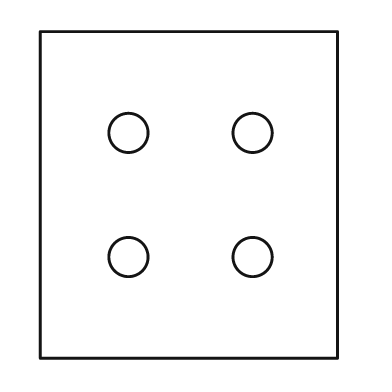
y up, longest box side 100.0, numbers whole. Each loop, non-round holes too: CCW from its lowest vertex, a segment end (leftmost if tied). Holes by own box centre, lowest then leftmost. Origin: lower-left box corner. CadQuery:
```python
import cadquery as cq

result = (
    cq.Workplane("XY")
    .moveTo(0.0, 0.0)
    .lineTo(91.0, 0.0)
    .lineTo(91.0, 100.0)
    .lineTo(0.0, 100.0)
    .close()
    .moveTo(27.0, 31.0)
    .circle(6.0)
    .moveTo(65.0, 31.0)
    .circle(6.0)
    .moveTo(27.0, 69.0)
    .circle(6.0)
    .moveTo(65.0, 69.0)
    .circle(6.0)
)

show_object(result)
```